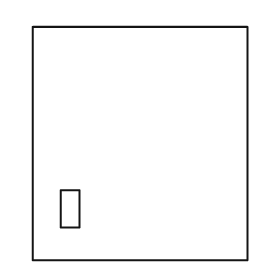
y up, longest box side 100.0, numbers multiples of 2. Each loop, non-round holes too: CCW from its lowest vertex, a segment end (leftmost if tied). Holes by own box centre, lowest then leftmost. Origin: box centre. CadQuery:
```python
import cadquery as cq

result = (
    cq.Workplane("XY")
    .moveTo(-46.0, -50.0)
    .lineTo(46.0, -50.0)
    .lineTo(46.0, 50.0)
    .lineTo(-46.0, 50.0)
    .close()
    .moveTo(-34.0, -36.0)
    .lineTo(-26.0, -36.0)
    .lineTo(-26.0, -20.0)
    .lineTo(-34.0, -20.0)
    .close()
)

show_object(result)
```